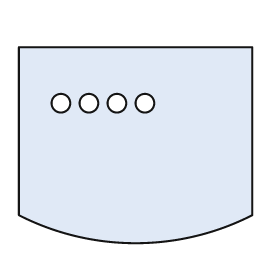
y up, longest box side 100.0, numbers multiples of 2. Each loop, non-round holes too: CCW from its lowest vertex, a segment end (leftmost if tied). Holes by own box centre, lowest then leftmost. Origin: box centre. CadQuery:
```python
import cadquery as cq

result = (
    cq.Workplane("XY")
    .moveTo(-50.0, -30.0)
    .threePointArc((0.0, -42.0), (50.0, -30.0))
    .lineTo(50.0, 42.0)
    .lineTo(-50.0, 42.0)
    .close()
    .moveTo(-32.0, 18.0)
    .circle(4.0)
    .moveTo(-20.0, 18.0)
    .circle(4.0)
    .moveTo(-8.0, 18.0)
    .circle(4.0)
    .moveTo(4.0, 18.0)
    .circle(4.0)
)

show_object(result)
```